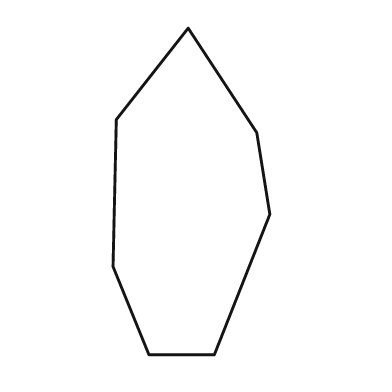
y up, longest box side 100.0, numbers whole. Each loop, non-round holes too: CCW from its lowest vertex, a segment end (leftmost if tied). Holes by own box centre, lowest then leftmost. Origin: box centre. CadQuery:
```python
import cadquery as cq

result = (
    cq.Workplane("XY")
    .moveTo(-13.0, -50.0)
    .lineTo(7.0, -50.0)
    .lineTo(24.0, -7.0)
    .lineTo(20.0, 18.0)
    .lineTo(-1.0, 50.0)
    .lineTo(-23.0, 22.0)
    .lineTo(-24.0, -23.0)
    .close()
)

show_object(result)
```